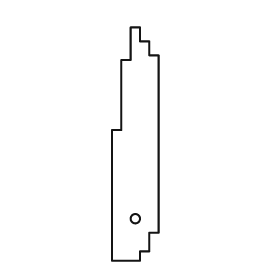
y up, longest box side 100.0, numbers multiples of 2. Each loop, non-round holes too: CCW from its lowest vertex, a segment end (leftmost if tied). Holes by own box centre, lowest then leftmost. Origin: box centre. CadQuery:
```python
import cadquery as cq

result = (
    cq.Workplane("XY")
    .moveTo(-10.0, -50.0)
    .lineTo(2.0, -50.0)
    .lineTo(2.0, -46.0)
    .lineTo(6.0, -46.0)
    .lineTo(6.0, -38.0)
    .lineTo(10.0, -38.0)
    .lineTo(10.0, 38.0)
    .lineTo(6.0, 38.0)
    .lineTo(6.0, 44.0)
    .lineTo(2.0, 44.0)
    .lineTo(2.0, 50.0)
    .lineTo(-2.0, 50.0)
    .lineTo(-2.0, 36.0)
    .lineTo(-6.0, 36.0)
    .lineTo(-6.0, 6.0)
    .lineTo(-10.0, 6.0)
    .close()
    .moveTo(0.0, -32.0)
    .circle(2.0)
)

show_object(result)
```